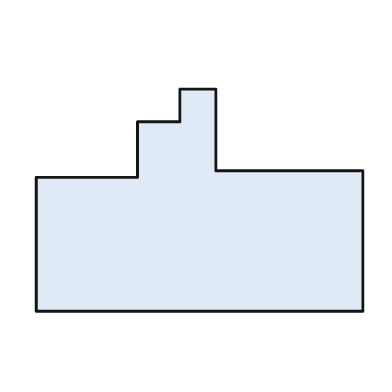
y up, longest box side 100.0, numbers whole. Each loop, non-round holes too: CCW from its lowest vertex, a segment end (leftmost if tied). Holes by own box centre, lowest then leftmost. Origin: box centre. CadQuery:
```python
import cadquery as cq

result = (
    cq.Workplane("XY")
    .moveTo(-50.0, -34.0)
    .lineTo(50.0, -34.0)
    .lineTo(50.0, 9.0)
    .lineTo(5.0, 9.0)
    .lineTo(5.0, 34.0)
    .lineTo(-6.0, 34.0)
    .lineTo(-6.0, 24.0)
    .lineTo(-19.0, 24.0)
    .lineTo(-19.0, 7.0)
    .lineTo(-50.0, 7.0)
    .close()
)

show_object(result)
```